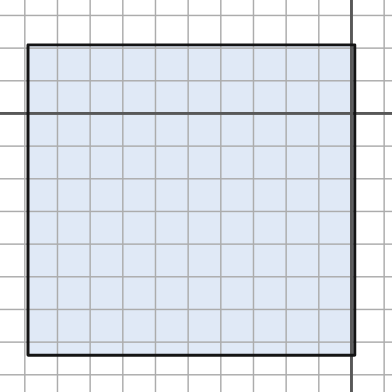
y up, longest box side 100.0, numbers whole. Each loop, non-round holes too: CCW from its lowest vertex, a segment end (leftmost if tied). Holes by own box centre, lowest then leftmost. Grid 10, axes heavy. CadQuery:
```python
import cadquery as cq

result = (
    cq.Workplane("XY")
    .moveTo(-99.0, -74.0)
    .lineTo(1.0, -74.0)
    .lineTo(1.0, 21.0)
    .lineTo(-99.0, 21.0)
    .close()
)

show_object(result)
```